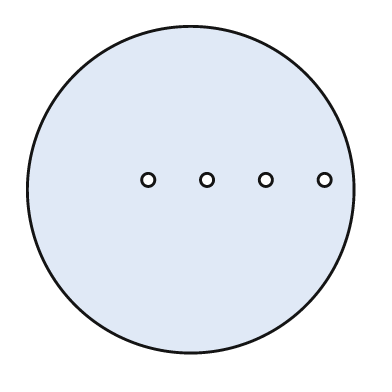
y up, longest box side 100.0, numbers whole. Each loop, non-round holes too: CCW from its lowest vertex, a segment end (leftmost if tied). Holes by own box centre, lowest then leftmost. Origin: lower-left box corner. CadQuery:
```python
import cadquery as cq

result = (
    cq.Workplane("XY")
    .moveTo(50.0, 50.0)
    .circle(50.0)
    .moveTo(37.0, 53.0)
    .circle(2.0)
    .moveTo(55.0, 53.0)
    .circle(2.0)
    .moveTo(73.0, 53.0)
    .circle(2.0)
    .moveTo(91.0, 53.0)
    .circle(2.0)
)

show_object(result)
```